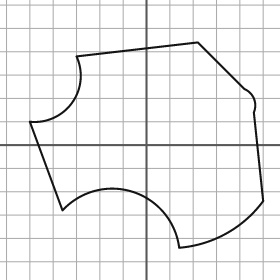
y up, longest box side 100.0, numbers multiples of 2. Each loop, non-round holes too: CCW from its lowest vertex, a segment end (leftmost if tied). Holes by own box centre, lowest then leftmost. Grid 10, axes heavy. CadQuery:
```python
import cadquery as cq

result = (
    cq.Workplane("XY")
    .moveTo(14.0, -44.0)
    .threePointArc((34.0, -38.0), (50.0, -24.0))
    .lineTo(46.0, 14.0)
    .threePointArc((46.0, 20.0), (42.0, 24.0))
    .lineTo(22.0, 44.0)
    .lineTo(-30.0, 38.0)
    .threePointArc((-32.0, 18.0), (-50.0, 10.0))
    .lineTo(-36.0, -28.0)
    .threePointArc((-6.0, -20.0), (14.0, -44.0))
    .close()
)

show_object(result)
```